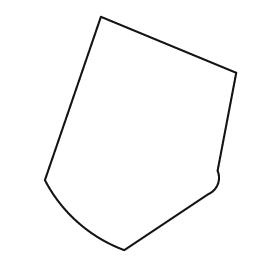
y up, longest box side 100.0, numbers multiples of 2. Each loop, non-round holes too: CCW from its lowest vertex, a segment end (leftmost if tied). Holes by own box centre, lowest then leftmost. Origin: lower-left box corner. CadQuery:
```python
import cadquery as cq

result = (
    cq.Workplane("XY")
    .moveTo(34.0, 0.0)
    .lineTo(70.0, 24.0)
    .threePointArc((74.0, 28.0), (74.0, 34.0))
    .lineTo(82.0, 76.0)
    .lineTo(24.0, 100.0)
    .lineTo(0.0, 30.0)
    .threePointArc((14.0, 12.0), (34.0, 0.0))
    .close()
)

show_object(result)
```